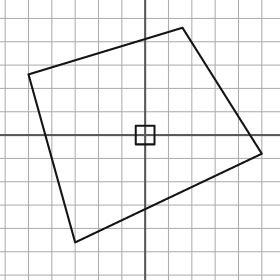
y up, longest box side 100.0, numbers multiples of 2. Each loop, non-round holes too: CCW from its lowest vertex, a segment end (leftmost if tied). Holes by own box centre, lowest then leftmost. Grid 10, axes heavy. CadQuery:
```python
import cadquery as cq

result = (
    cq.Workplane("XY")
    .moveTo(-30.0, -46.0)
    .lineTo(50.0, -8.0)
    .lineTo(16.0, 46.0)
    .lineTo(-50.0, 26.0)
    .close()
    .moveTo(-4.0, -4.0)
    .lineTo(4.0, -4.0)
    .lineTo(4.0, 4.0)
    .lineTo(-4.0, 4.0)
    .close()
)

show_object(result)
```